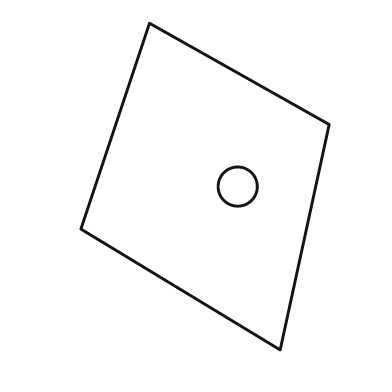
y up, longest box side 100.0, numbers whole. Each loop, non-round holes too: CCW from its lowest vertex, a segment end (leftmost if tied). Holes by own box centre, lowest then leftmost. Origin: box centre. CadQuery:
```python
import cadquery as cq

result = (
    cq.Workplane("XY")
    .moveTo(23.0, -50.0)
    .lineTo(38.0, 19.0)
    .lineTo(-17.0, 50.0)
    .lineTo(-38.0, -13.0)
    .close()
    .moveTo(10.0, 0.0)
    .circle(6.0)
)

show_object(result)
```